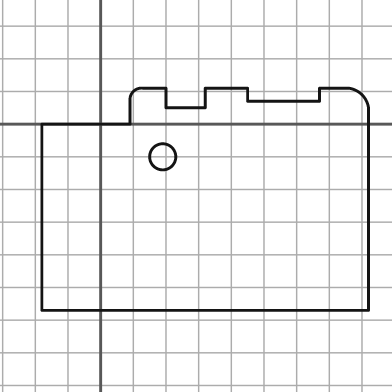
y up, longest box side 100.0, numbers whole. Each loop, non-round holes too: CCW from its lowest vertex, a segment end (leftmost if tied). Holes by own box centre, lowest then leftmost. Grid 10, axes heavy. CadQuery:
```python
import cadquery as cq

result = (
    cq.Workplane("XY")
    .moveTo(-18.0, -57.0)
    .lineTo(82.0, -57.0)
    .lineTo(82.0, 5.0)
    .threePointArc((80.0, 9.0), (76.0, 11.0))
    .lineTo(67.0, 11.0)
    .lineTo(67.0, 7.0)
    .lineTo(45.0, 7.0)
    .lineTo(45.0, 11.0)
    .lineTo(32.0, 11.0)
    .lineTo(32.0, 5.0)
    .lineTo(20.0, 5.0)
    .lineTo(20.0, 11.0)
    .lineTo(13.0, 11.0)
    .threePointArc((10.0, 10.0), (9.0, 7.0))
    .lineTo(9.0, 0.0)
    .lineTo(-18.0, 0.0)
    .close()
    .moveTo(19.0, -10.0)
    .circle(4.0)
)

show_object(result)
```